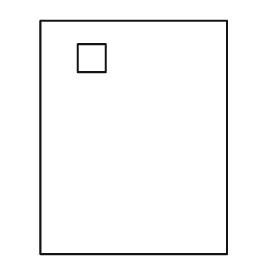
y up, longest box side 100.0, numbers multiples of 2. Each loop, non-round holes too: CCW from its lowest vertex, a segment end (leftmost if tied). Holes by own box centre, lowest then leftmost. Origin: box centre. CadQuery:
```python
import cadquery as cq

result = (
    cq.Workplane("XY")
    .moveTo(-40.0, -50.0)
    .lineTo(40.0, -50.0)
    .lineTo(40.0, 50.0)
    .lineTo(-40.0, 50.0)
    .close()
    .moveTo(-24.0, 28.0)
    .lineTo(-12.0, 28.0)
    .lineTo(-12.0, 40.0)
    .lineTo(-24.0, 40.0)
    .close()
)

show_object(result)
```